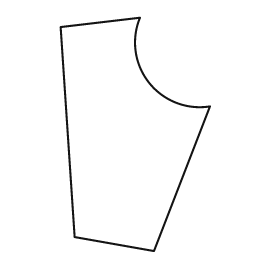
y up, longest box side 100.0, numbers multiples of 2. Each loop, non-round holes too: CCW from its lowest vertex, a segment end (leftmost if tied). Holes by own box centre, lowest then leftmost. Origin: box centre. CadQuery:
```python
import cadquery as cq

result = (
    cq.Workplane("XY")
    .moveTo(8.0, -50.0)
    .lineTo(32.0, 12.0)
    .threePointArc((6.0, 22.0), (2.0, 50.0))
    .lineTo(-32.0, 46.0)
    .lineTo(-26.0, -44.0)
    .close()
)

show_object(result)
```